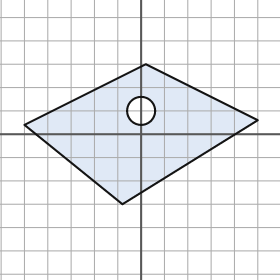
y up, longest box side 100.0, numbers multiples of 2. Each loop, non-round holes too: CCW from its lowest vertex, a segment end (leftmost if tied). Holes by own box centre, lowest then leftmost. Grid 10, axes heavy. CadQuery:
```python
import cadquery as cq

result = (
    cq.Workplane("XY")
    .moveTo(-8.0, -30.0)
    .lineTo(50.0, 6.0)
    .lineTo(2.0, 30.0)
    .lineTo(-50.0, 4.0)
    .close()
    .moveTo(0.0, 10.0)
    .circle(6.0)
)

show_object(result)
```